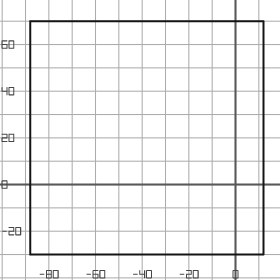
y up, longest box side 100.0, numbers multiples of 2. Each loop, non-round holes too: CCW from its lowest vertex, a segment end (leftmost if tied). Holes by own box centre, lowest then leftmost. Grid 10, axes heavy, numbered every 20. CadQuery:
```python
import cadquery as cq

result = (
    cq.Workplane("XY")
    .moveTo(-88.0, -30.0)
    .lineTo(12.0, -30.0)
    .lineTo(12.0, 70.0)
    .lineTo(-88.0, 70.0)
    .close()
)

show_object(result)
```